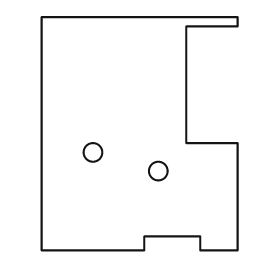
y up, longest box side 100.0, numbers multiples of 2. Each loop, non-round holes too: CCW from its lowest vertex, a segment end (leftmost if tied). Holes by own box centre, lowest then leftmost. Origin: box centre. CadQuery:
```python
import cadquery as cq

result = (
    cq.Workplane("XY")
    .moveTo(-42.0, -50.0)
    .lineTo(2.0, -50.0)
    .lineTo(2.0, -44.0)
    .lineTo(26.0, -44.0)
    .lineTo(26.0, -50.0)
    .lineTo(42.0, -50.0)
    .lineTo(42.0, -4.0)
    .lineTo(20.0, -4.0)
    .lineTo(20.0, 46.0)
    .lineTo(42.0, 46.0)
    .lineTo(42.0, 50.0)
    .lineTo(-42.0, 50.0)
    .close()
    .moveTo(8.0, -16.0)
    .circle(4.0)
    .moveTo(-20.0, -8.0)
    .circle(4.0)
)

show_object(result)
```